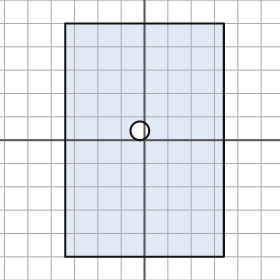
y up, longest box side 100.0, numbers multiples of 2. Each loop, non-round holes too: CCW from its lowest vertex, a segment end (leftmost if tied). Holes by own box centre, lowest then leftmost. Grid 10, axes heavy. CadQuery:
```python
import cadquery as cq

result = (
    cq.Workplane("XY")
    .moveTo(-34.0, -50.0)
    .lineTo(34.0, -50.0)
    .lineTo(34.0, 50.0)
    .lineTo(-34.0, 50.0)
    .close()
    .moveTo(-2.0, 4.0)
    .circle(4.0)
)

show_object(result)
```